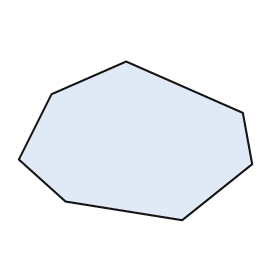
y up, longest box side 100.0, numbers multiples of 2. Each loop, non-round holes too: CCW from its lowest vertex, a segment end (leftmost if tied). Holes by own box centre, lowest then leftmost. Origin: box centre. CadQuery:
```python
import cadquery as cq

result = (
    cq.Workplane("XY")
    .moveTo(20.0, -34.0)
    .lineTo(50.0, -10.0)
    .lineTo(46.0, 12.0)
    .lineTo(-4.0, 34.0)
    .lineTo(-36.0, 20.0)
    .lineTo(-50.0, -8.0)
    .lineTo(-30.0, -26.0)
    .close()
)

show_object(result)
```